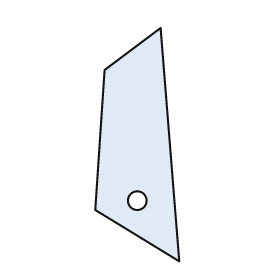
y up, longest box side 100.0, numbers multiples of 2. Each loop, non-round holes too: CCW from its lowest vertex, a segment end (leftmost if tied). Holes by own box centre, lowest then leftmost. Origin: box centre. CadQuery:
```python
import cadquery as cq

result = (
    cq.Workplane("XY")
    .moveTo(18.0, -50.0)
    .lineTo(10.0, 50.0)
    .lineTo(-14.0, 32.0)
    .lineTo(-18.0, -28.0)
    .close()
    .moveTo(0.0, -24.0)
    .circle(4.0)
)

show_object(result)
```